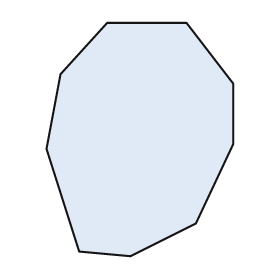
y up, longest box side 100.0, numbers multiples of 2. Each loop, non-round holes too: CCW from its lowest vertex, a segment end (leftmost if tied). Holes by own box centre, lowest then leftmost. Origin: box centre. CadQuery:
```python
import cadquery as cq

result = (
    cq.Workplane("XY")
    .moveTo(-4.0, -50.0)
    .lineTo(24.0, -36.0)
    .lineTo(40.0, -2.0)
    .lineTo(40.0, 24.0)
    .lineTo(20.0, 50.0)
    .lineTo(-14.0, 50.0)
    .lineTo(-34.0, 28.0)
    .lineTo(-40.0, -4.0)
    .lineTo(-26.0, -48.0)
    .close()
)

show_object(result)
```